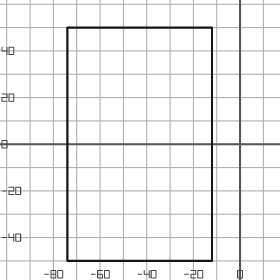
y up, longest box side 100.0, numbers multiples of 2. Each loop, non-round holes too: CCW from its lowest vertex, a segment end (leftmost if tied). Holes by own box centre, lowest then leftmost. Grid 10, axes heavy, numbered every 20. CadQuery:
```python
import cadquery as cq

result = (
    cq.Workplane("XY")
    .moveTo(-74.0, -50.0)
    .lineTo(-12.0, -50.0)
    .lineTo(-12.0, 50.0)
    .lineTo(-74.0, 50.0)
    .close()
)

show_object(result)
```